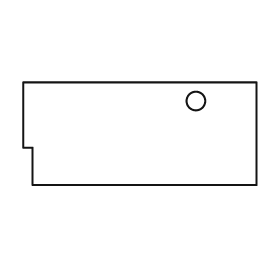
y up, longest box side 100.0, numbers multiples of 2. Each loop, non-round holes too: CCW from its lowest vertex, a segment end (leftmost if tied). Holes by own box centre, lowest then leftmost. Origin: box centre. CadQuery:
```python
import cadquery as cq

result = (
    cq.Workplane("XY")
    .moveTo(-46.0, -22.0)
    .lineTo(50.0, -22.0)
    .lineTo(50.0, 22.0)
    .lineTo(-50.0, 22.0)
    .lineTo(-50.0, -6.0)
    .lineTo(-46.0, -6.0)
    .close()
    .moveTo(24.0, 14.0)
    .circle(4.0)
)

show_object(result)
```